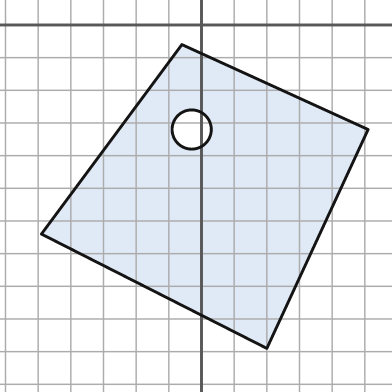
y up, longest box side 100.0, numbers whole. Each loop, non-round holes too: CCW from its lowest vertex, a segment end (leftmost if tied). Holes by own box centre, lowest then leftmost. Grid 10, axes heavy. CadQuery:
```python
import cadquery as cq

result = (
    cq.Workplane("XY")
    .moveTo(20.0, -99.0)
    .lineTo(51.0, -32.0)
    .lineTo(-6.0, -6.0)
    .lineTo(-49.0, -64.0)
    .close()
    .moveTo(-3.0, -32.0)
    .circle(6.0)
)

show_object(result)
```